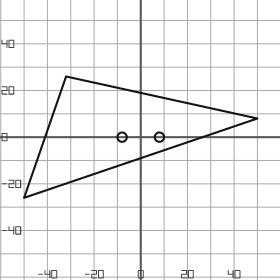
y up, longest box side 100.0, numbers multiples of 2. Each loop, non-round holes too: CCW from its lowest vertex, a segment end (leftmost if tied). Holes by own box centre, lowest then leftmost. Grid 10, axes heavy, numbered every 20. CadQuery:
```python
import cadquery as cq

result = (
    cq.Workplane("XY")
    .moveTo(-50.0, -26.0)
    .lineTo(50.0, 8.0)
    .lineTo(-32.0, 26.0)
    .close()
    .moveTo(-8.0, 0.0)
    .circle(2.0)
    .moveTo(8.0, 0.0)
    .circle(2.0)
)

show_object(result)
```